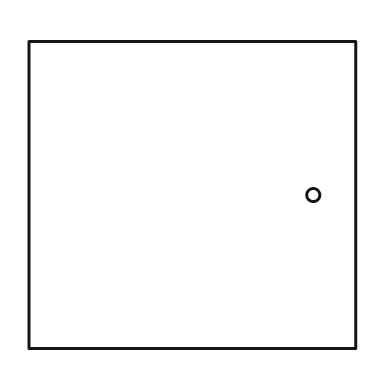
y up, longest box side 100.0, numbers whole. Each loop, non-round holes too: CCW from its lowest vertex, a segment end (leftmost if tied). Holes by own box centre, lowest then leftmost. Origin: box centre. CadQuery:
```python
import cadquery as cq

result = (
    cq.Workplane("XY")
    .moveTo(-50.0, -47.0)
    .lineTo(50.0, -47.0)
    .lineTo(50.0, 47.0)
    .lineTo(-50.0, 47.0)
    .close()
    .moveTo(37.0, 0.0)
    .circle(2.0)
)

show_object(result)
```